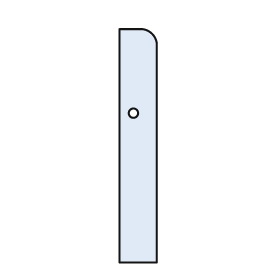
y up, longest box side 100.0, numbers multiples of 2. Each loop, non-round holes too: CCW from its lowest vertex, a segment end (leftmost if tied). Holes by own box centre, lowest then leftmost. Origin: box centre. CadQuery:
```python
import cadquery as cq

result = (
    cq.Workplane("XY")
    .moveTo(-8.0, -50.0)
    .lineTo(8.0, -50.0)
    .lineTo(8.0, 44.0)
    .threePointArc((6.0, 48.0), (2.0, 50.0))
    .lineTo(-8.0, 50.0)
    .close()
    .moveTo(-2.0, 14.0)
    .circle(2.0)
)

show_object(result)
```